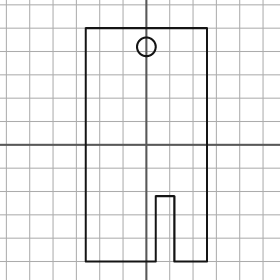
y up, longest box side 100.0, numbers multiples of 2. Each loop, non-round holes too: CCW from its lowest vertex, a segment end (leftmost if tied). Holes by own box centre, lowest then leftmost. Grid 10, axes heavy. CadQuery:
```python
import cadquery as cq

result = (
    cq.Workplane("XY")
    .moveTo(-26.0, -50.0)
    .lineTo(4.0, -50.0)
    .lineTo(4.0, -22.0)
    .lineTo(12.0, -22.0)
    .lineTo(12.0, -50.0)
    .lineTo(26.0, -50.0)
    .lineTo(26.0, 50.0)
    .lineTo(-26.0, 50.0)
    .close()
    .moveTo(0.0, 42.0)
    .circle(4.0)
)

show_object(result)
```